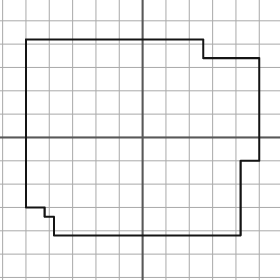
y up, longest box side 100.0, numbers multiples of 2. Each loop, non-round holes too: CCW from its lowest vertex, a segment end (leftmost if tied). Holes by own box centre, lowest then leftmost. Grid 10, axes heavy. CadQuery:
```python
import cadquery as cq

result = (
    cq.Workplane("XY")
    .moveTo(-38.0, -42.0)
    .lineTo(42.0, -42.0)
    .lineTo(42.0, -10.0)
    .lineTo(50.0, -10.0)
    .lineTo(50.0, 34.0)
    .lineTo(26.0, 34.0)
    .lineTo(26.0, 42.0)
    .lineTo(-50.0, 42.0)
    .lineTo(-50.0, -30.0)
    .lineTo(-42.0, -30.0)
    .lineTo(-42.0, -34.0)
    .lineTo(-38.0, -34.0)
    .close()
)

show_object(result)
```